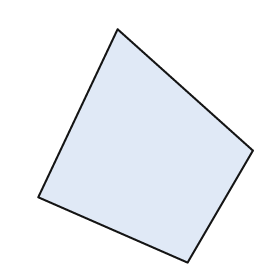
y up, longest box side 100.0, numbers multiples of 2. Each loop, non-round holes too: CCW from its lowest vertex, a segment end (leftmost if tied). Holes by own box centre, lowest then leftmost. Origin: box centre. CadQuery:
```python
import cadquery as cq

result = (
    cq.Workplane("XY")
    .moveTo(18.0, -50.0)
    .lineTo(46.0, -2.0)
    .lineTo(-12.0, 50.0)
    .lineTo(-46.0, -22.0)
    .close()
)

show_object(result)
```